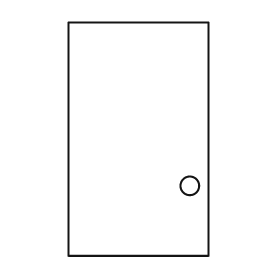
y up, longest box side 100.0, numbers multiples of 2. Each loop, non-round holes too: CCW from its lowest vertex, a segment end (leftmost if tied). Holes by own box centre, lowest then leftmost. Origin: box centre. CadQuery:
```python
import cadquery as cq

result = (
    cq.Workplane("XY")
    .moveTo(-30.0, -50.0)
    .lineTo(30.0, -50.0)
    .lineTo(30.0, 50.0)
    .lineTo(-30.0, 50.0)
    .close()
    .moveTo(22.0, -20.0)
    .circle(4.0)
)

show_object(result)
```